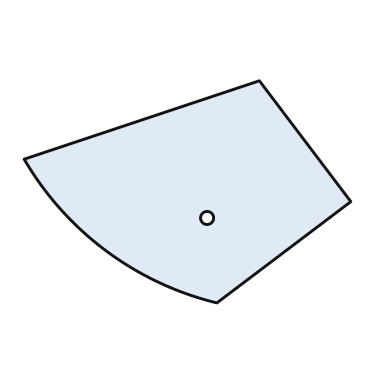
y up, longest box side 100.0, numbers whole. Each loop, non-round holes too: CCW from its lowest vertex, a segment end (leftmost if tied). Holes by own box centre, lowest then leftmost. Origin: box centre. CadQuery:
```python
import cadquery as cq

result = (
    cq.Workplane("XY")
    .moveTo(9.0, -34.0)
    .lineTo(50.0, -3.0)
    .lineTo(22.0, 34.0)
    .lineTo(-50.0, 10.0)
    .threePointArc((-25.0, -18.0), (9.0, -34.0))
    .close()
    .moveTo(6.0, -8.0)
    .circle(2.0)
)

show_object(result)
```